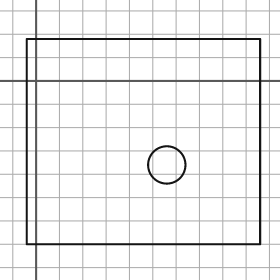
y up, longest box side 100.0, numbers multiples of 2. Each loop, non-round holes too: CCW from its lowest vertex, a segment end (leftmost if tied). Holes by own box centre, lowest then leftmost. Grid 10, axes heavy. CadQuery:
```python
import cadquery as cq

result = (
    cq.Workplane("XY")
    .moveTo(-4.0, -70.0)
    .lineTo(96.0, -70.0)
    .lineTo(96.0, 18.0)
    .lineTo(-4.0, 18.0)
    .close()
    .moveTo(56.0, -36.0)
    .circle(8.0)
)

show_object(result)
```